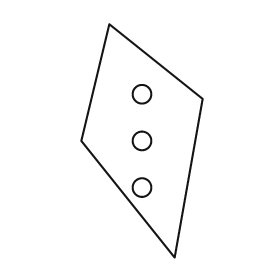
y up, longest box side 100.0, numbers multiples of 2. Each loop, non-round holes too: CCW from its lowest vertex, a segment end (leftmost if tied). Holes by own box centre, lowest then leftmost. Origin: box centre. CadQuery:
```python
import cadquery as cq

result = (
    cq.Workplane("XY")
    .moveTo(14.0, -50.0)
    .lineTo(26.0, 18.0)
    .lineTo(-14.0, 50.0)
    .lineTo(-26.0, 0.0)
    .close()
    .moveTo(0.0, -20.0)
    .circle(4.0)
    .moveTo(0.0, 0.0)
    .circle(4.0)
    .moveTo(0.0, 20.0)
    .circle(4.0)
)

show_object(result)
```